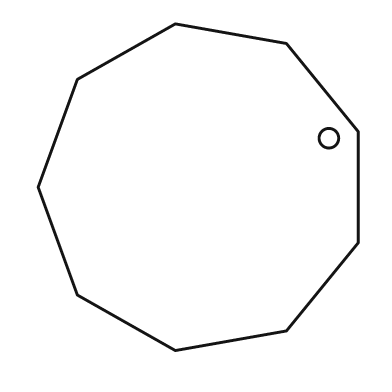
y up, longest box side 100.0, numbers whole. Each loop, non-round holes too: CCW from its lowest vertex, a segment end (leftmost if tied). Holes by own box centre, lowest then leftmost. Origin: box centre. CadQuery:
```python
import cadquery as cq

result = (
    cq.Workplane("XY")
    .moveTo(-7.0, -50.0)
    .lineTo(27.0, -44.0)
    .lineTo(49.0, -17.0)
    .lineTo(49.0, 17.0)
    .lineTo(27.0, 44.0)
    .lineTo(-7.0, 50.0)
    .lineTo(-37.0, 33.0)
    .lineTo(-49.0, 0.0)
    .lineTo(-37.0, -33.0)
    .close()
    .moveTo(40.0, 15.0)
    .circle(3.0)
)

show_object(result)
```